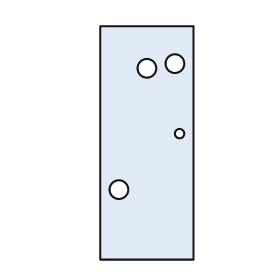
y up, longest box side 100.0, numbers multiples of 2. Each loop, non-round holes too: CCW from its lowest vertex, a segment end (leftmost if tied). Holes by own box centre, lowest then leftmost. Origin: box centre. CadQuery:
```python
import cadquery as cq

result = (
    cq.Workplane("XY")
    .moveTo(-20.0, -50.0)
    .lineTo(20.0, -50.0)
    .lineTo(20.0, 50.0)
    .lineTo(-20.0, 50.0)
    .close()
    .moveTo(-12.0, -20.0)
    .circle(4.0)
    .moveTo(14.0, 4.0)
    .circle(2.0)
    .moveTo(0.0, 32.0)
    .circle(4.0)
    .moveTo(12.0, 34.0)
    .circle(4.0)
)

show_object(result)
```